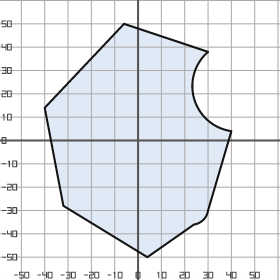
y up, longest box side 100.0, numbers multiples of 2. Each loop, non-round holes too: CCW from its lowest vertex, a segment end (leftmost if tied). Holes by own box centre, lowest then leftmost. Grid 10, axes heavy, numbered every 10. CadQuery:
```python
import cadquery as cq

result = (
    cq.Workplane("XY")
    .moveTo(4.0, -50.0)
    .lineTo(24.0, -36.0)
    .threePointArc((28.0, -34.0), (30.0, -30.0))
    .lineTo(40.0, 4.0)
    .threePointArc((24.0, 18.0), (30.0, 38.0))
    .lineTo(-6.0, 50.0)
    .lineTo(-40.0, 14.0)
    .lineTo(-32.0, -28.0)
    .close()
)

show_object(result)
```